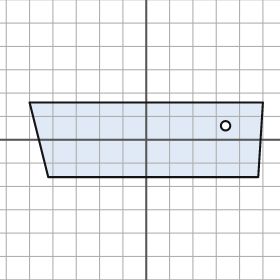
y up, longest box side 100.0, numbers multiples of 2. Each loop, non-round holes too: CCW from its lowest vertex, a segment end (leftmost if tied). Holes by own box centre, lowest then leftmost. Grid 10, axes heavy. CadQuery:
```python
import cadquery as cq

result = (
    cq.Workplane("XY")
    .moveTo(-42.0, -16.0)
    .lineTo(48.0, -16.0)
    .lineTo(50.0, 16.0)
    .lineTo(-50.0, 16.0)
    .close()
    .moveTo(34.0, 6.0)
    .circle(2.0)
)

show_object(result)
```